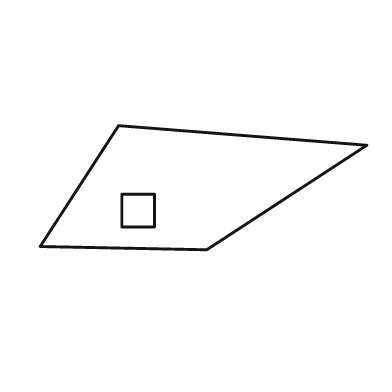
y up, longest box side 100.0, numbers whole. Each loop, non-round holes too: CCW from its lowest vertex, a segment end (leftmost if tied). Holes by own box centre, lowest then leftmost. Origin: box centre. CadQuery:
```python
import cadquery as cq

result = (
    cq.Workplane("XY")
    .moveTo(1.0, -19.0)
    .lineTo(50.0, 13.0)
    .lineTo(-26.0, 19.0)
    .lineTo(-50.0, -18.0)
    .close()
    .moveTo(-25.0, -12.0)
    .lineTo(-15.0, -12.0)
    .lineTo(-15.0, -2.0)
    .lineTo(-25.0, -2.0)
    .close()
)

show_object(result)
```